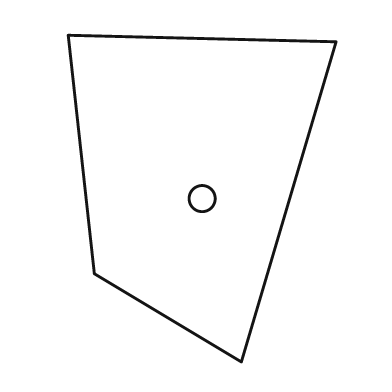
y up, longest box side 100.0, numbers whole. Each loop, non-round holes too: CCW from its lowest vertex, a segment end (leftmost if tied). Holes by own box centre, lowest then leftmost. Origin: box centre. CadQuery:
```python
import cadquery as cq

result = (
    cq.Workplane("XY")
    .moveTo(12.0, -50.0)
    .lineTo(41.0, 48.0)
    .lineTo(-41.0, 50.0)
    .lineTo(-33.0, -23.0)
    .close()
    .moveTo(0.0, 0.0)
    .circle(4.0)
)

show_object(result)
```